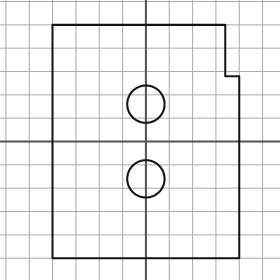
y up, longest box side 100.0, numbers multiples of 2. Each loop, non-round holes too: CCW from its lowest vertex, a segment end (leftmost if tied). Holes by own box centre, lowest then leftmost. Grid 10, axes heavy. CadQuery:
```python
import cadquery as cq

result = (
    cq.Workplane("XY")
    .moveTo(-40.0, -50.0)
    .lineTo(40.0, -50.0)
    .lineTo(40.0, 28.0)
    .lineTo(34.0, 28.0)
    .lineTo(34.0, 50.0)
    .lineTo(-40.0, 50.0)
    .close()
    .moveTo(0.0, -16.0)
    .circle(8.0)
    .moveTo(0.0, 16.0)
    .circle(8.0)
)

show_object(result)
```